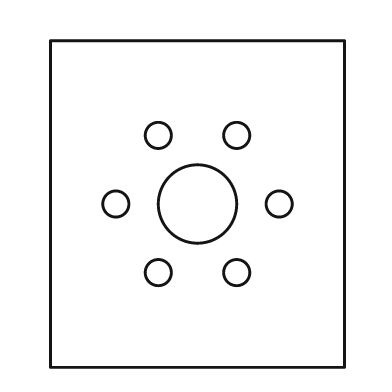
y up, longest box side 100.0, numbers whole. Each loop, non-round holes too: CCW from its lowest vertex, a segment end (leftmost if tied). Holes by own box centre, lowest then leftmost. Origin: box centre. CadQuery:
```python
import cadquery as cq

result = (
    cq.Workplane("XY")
    .moveTo(-45.0, -50.0)
    .lineTo(45.0, -50.0)
    .lineTo(45.0, 50.0)
    .lineTo(-45.0, 50.0)
    .close()
    .moveTo(-12.0, -21.0)
    .circle(4.0)
    .moveTo(12.0, -21.0)
    .circle(4.0)
    .moveTo(-25.0, 0.0)
    .circle(4.0)
    .moveTo(0.0, 0.0)
    .circle(12.0)
    .moveTo(25.0, 0.0)
    .circle(4.0)
    .moveTo(-12.0, 21.0)
    .circle(4.0)
    .moveTo(12.0, 21.0)
    .circle(4.0)
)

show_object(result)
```